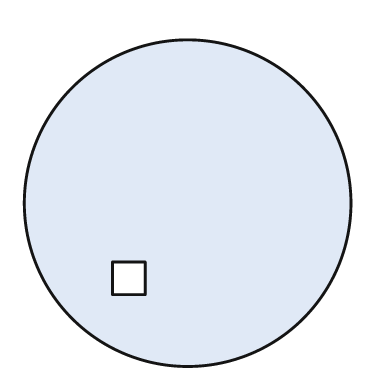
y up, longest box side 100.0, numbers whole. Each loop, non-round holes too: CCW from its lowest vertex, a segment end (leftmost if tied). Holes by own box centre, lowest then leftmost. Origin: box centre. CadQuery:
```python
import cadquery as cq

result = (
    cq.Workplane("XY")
    .moveTo(0.0, 0.0)
    .circle(50.0)
    .moveTo(-23.0, -28.0)
    .lineTo(-13.0, -28.0)
    .lineTo(-13.0, -18.0)
    .lineTo(-23.0, -18.0)
    .close()
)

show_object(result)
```